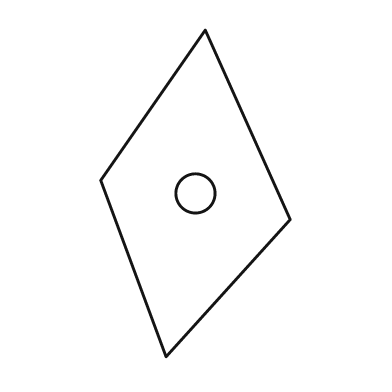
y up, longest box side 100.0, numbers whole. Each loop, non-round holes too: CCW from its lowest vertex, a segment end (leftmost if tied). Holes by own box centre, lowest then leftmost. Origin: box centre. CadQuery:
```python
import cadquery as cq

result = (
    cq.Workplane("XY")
    .moveTo(-9.0, -50.0)
    .lineTo(29.0, -8.0)
    .lineTo(3.0, 50.0)
    .lineTo(-29.0, 4.0)
    .close()
    .moveTo(0.0, 0.0)
    .circle(6.0)
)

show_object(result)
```